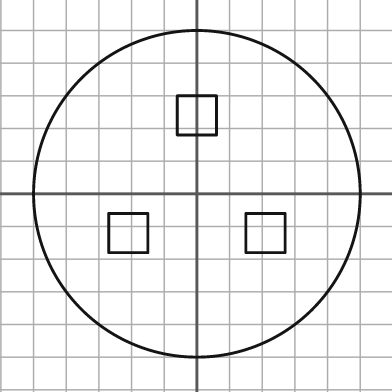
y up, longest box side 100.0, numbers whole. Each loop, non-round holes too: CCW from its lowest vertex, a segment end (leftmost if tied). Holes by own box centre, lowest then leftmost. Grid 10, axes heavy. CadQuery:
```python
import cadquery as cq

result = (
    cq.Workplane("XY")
    .moveTo(0.0, 0.0)
    .circle(50.0)
    .moveTo(-27.0, -18.0)
    .lineTo(-15.0, -18.0)
    .lineTo(-15.0, -6.0)
    .lineTo(-27.0, -6.0)
    .close()
    .moveTo(15.0, -18.0)
    .lineTo(27.0, -18.0)
    .lineTo(27.0, -6.0)
    .lineTo(15.0, -6.0)
    .close()
    .moveTo(-6.0, 18.0)
    .lineTo(6.0, 18.0)
    .lineTo(6.0, 30.0)
    .lineTo(-6.0, 30.0)
    .close()
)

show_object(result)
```